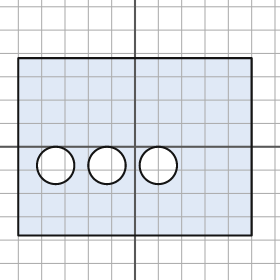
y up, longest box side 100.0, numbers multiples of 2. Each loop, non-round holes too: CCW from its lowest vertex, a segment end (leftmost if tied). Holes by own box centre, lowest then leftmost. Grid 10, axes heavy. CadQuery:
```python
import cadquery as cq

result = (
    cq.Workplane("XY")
    .moveTo(-50.0, -38.0)
    .lineTo(50.0, -38.0)
    .lineTo(50.0, 38.0)
    .lineTo(-50.0, 38.0)
    .close()
    .moveTo(-34.0, -8.0)
    .circle(8.0)
    .moveTo(-12.0, -8.0)
    .circle(8.0)
    .moveTo(10.0, -8.0)
    .circle(8.0)
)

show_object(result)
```